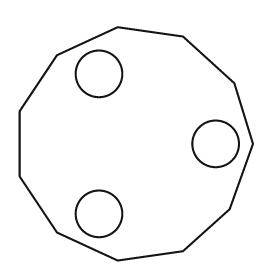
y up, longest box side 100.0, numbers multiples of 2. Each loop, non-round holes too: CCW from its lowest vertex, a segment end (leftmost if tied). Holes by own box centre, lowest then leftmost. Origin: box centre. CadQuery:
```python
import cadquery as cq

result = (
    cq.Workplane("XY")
    .moveTo(-8.0, -50.0)
    .lineTo(20.0, -46.0)
    .lineTo(40.0, -28.0)
    .lineTo(50.0, 0.0)
    .lineTo(42.0, 26.0)
    .lineTo(20.0, 46.0)
    .lineTo(-8.0, 50.0)
    .lineTo(-34.0, 38.0)
    .lineTo(-50.0, 14.0)
    .lineTo(-50.0, -14.0)
    .lineTo(-34.0, -38.0)
    .close()
    .moveTo(-16.0, -30.0)
    .circle(10.0)
    .moveTo(34.0, 0.0)
    .circle(10.0)
    .moveTo(-16.0, 30.0)
    .circle(10.0)
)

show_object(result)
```